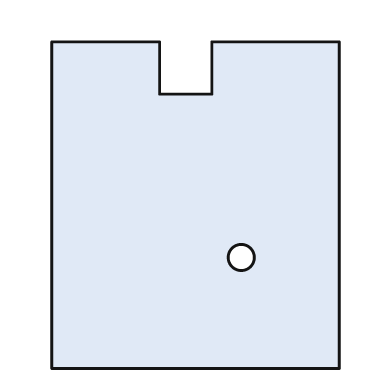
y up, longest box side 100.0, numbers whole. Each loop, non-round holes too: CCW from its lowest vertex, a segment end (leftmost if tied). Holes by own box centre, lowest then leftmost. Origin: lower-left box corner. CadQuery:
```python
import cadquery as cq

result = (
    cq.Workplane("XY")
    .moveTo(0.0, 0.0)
    .lineTo(88.0, 0.0)
    .lineTo(88.0, 100.0)
    .lineTo(49.0, 100.0)
    .lineTo(49.0, 84.0)
    .lineTo(33.0, 84.0)
    .lineTo(33.0, 100.0)
    .lineTo(0.0, 100.0)
    .close()
    .moveTo(58.0, 34.0)
    .circle(4.0)
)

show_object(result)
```